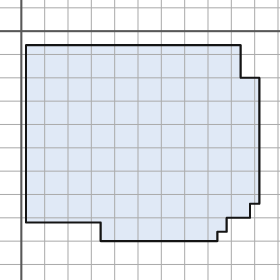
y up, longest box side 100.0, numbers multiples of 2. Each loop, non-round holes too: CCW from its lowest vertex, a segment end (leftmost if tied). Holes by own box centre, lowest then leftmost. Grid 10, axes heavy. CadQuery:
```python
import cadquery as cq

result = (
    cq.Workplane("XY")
    .moveTo(34.0, -90.0)
    .lineTo(84.0, -90.0)
    .lineTo(84.0, -86.0)
    .lineTo(88.0, -86.0)
    .lineTo(88.0, -80.0)
    .lineTo(98.0, -80.0)
    .lineTo(98.0, -74.0)
    .lineTo(102.0, -74.0)
    .lineTo(102.0, -20.0)
    .lineTo(94.0, -20.0)
    .lineTo(94.0, -6.0)
    .lineTo(2.0, -6.0)
    .lineTo(2.0, -82.0)
    .lineTo(34.0, -82.0)
    .close()
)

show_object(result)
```